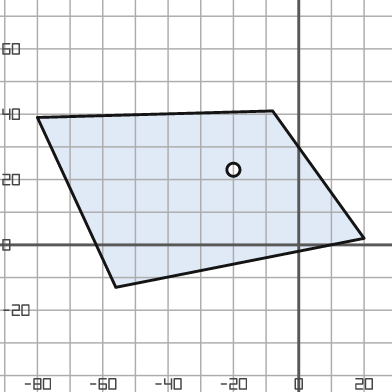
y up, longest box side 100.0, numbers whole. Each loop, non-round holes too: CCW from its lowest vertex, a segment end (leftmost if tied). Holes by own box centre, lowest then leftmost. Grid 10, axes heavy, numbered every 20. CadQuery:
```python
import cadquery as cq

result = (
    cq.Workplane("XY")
    .moveTo(-56.0, -13.0)
    .lineTo(20.0, 2.0)
    .lineTo(-8.0, 41.0)
    .lineTo(-80.0, 39.0)
    .close()
    .moveTo(-20.0, 23.0)
    .circle(2.0)
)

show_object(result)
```